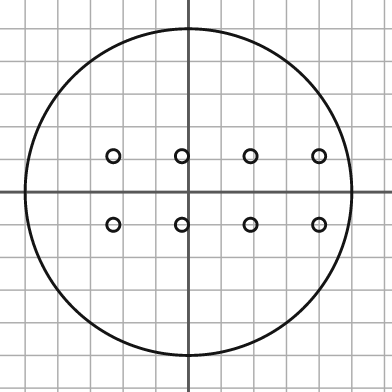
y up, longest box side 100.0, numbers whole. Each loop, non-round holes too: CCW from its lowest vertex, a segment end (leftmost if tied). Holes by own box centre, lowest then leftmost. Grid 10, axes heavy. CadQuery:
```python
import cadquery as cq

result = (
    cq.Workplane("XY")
    .moveTo(0.0, 0.0)
    .circle(50.0)
    .moveTo(-23.0, -10.0)
    .circle(2.0)
    .moveTo(-2.0, -10.0)
    .circle(2.0)
    .moveTo(19.0, -10.0)
    .circle(2.0)
    .moveTo(40.0, -10.0)
    .circle(2.0)
    .moveTo(-23.0, 11.0)
    .circle(2.0)
    .moveTo(-2.0, 11.0)
    .circle(2.0)
    .moveTo(19.0, 11.0)
    .circle(2.0)
    .moveTo(40.0, 11.0)
    .circle(2.0)
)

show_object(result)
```